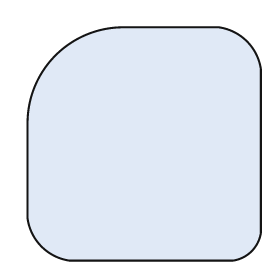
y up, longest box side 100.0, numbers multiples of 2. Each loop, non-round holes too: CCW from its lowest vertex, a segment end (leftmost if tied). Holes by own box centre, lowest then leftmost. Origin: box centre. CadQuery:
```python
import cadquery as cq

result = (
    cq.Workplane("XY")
    .moveTo(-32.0, -50.0)
    .lineTo(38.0, -50.0)
    .threePointArc((46.0, -46.0), (50.0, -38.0))
    .lineTo(50.0, 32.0)
    .threePointArc((44.0, 44.0), (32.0, 50.0))
    .lineTo(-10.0, 50.0)
    .threePointArc((-38.0, 38.0), (-50.0, 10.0))
    .lineTo(-50.0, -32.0)
    .threePointArc((-44.0, -44.0), (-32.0, -50.0))
    .close()
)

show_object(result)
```